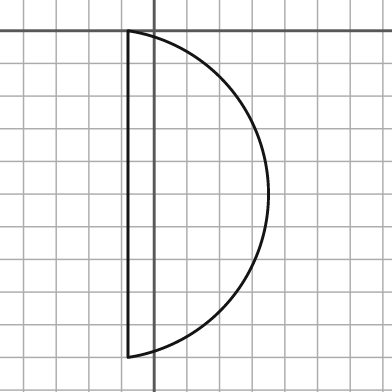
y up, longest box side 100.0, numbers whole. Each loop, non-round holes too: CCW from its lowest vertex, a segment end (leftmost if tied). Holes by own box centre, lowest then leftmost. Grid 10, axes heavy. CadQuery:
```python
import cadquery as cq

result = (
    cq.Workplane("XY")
    .moveTo(-8.0, -100.0)
    .threePointArc((35.0, -50.0), (-8.0, 0.0))
    .close()
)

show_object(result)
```